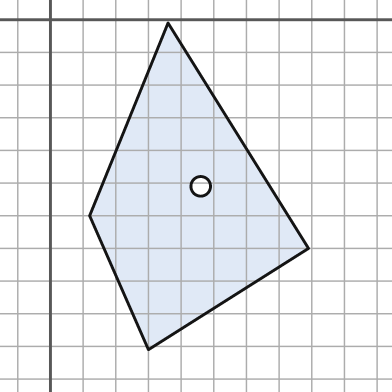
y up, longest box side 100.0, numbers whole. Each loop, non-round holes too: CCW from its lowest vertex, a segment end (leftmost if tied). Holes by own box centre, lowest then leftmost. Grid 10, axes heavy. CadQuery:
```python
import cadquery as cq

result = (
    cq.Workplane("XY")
    .moveTo(30.0, -101.0)
    .lineTo(79.0, -70.0)
    .lineTo(36.0, -1.0)
    .lineTo(12.0, -60.0)
    .close()
    .moveTo(46.0, -51.0)
    .circle(3.0)
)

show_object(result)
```